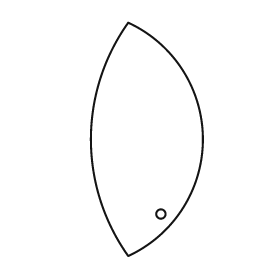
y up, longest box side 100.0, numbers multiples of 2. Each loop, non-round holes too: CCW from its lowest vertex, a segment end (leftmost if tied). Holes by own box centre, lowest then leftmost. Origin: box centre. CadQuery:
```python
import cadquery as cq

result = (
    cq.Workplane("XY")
    .moveTo(-8.0, -50.0)
    .threePointArc((24.0, 0.0), (-8.0, 50.0))
    .threePointArc((-24.0, 0.0), (-8.0, -50.0))
    .close()
    .moveTo(6.0, -32.0)
    .circle(2.0)
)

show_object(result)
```